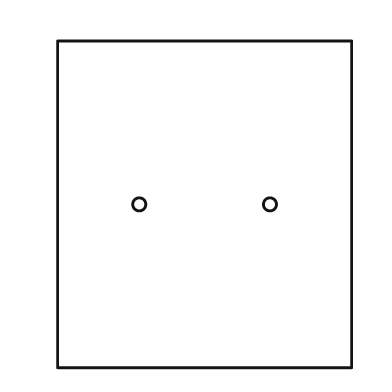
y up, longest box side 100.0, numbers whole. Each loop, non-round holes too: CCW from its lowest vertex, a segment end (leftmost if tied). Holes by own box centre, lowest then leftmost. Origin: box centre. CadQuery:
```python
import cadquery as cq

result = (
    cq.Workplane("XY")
    .moveTo(-45.0, -50.0)
    .lineTo(45.0, -50.0)
    .lineTo(45.0, 50.0)
    .lineTo(-45.0, 50.0)
    .close()
    .moveTo(-20.0, 0.0)
    .circle(2.0)
    .moveTo(20.0, 0.0)
    .circle(2.0)
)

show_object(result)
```